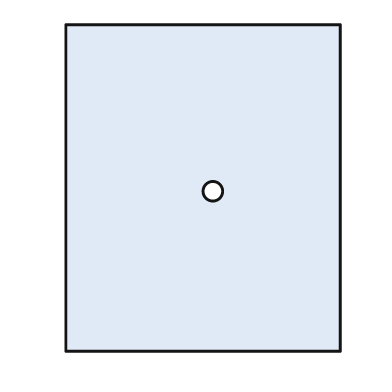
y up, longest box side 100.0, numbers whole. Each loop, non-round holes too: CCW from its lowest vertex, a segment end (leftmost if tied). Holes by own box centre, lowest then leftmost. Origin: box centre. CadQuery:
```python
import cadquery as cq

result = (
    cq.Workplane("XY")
    .moveTo(-42.0, -50.0)
    .lineTo(42.0, -50.0)
    .lineTo(42.0, 50.0)
    .lineTo(-42.0, 50.0)
    .close()
    .moveTo(3.0, -1.0)
    .circle(3.0)
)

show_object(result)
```